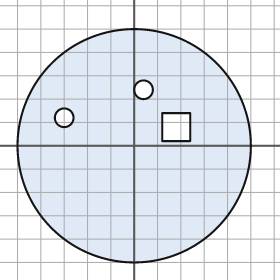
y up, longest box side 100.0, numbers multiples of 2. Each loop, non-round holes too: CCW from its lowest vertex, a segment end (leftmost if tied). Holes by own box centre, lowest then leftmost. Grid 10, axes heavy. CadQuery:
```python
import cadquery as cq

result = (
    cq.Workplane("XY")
    .moveTo(0.0, 0.0)
    .circle(50.0)
    .moveTo(12.0, 2.0)
    .lineTo(24.0, 2.0)
    .lineTo(24.0, 14.0)
    .lineTo(12.0, 14.0)
    .close()
    .moveTo(-30.0, 12.0)
    .circle(4.0)
    .moveTo(4.0, 24.0)
    .circle(4.0)
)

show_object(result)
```